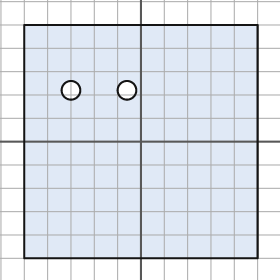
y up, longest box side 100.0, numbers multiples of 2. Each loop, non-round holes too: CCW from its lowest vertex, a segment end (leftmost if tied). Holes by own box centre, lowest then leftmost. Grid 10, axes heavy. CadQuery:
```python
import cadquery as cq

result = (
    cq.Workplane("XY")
    .moveTo(-50.0, -50.0)
    .lineTo(50.0, -50.0)
    .lineTo(50.0, 50.0)
    .lineTo(-50.0, 50.0)
    .close()
    .moveTo(-30.0, 22.0)
    .circle(4.0)
    .moveTo(-6.0, 22.0)
    .circle(4.0)
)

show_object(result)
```